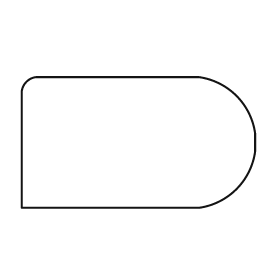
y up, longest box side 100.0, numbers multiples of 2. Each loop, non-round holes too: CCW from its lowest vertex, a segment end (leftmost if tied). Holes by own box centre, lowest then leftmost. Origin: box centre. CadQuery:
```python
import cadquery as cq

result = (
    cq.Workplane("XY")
    .moveTo(-50.0, -28.0)
    .lineTo(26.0, -28.0)
    .threePointArc((42.0, -20.0), (50.0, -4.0))
    .lineTo(50.0, 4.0)
    .threePointArc((42.0, 20.0), (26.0, 28.0))
    .lineTo(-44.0, 28.0)
    .threePointArc((-48.0, 26.0), (-50.0, 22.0))
    .close()
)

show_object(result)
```